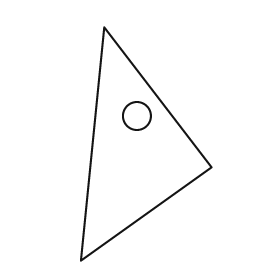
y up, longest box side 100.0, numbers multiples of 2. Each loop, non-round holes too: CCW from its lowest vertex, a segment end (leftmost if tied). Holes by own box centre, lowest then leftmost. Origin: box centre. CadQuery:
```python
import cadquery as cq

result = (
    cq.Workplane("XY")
    .moveTo(-28.0, -50.0)
    .lineTo(28.0, -10.0)
    .lineTo(-18.0, 50.0)
    .close()
    .moveTo(-4.0, 12.0)
    .circle(6.0)
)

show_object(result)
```